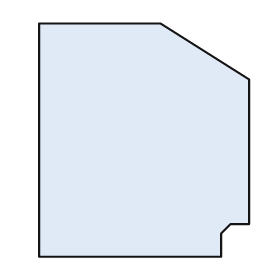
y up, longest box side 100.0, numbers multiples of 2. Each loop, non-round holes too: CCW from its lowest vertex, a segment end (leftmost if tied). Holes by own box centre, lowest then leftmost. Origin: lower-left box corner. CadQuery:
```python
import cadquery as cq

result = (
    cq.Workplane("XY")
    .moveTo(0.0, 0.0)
    .lineTo(78.0, 0.0)
    .lineTo(78.0, 10.0)
    .lineTo(82.0, 14.0)
    .lineTo(90.0, 14.0)
    .lineTo(90.0, 76.0)
    .lineTo(52.0, 100.0)
    .lineTo(0.0, 100.0)
    .close()
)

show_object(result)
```